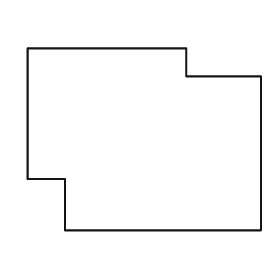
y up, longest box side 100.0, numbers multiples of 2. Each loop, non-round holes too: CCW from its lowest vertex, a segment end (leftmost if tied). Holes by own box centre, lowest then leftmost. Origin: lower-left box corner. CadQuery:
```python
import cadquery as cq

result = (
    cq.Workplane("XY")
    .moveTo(16.0, 0.0)
    .lineTo(100.0, 0.0)
    .lineTo(100.0, 66.0)
    .lineTo(68.0, 66.0)
    .lineTo(68.0, 78.0)
    .lineTo(0.0, 78.0)
    .lineTo(0.0, 22.0)
    .lineTo(16.0, 22.0)
    .close()
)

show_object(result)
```